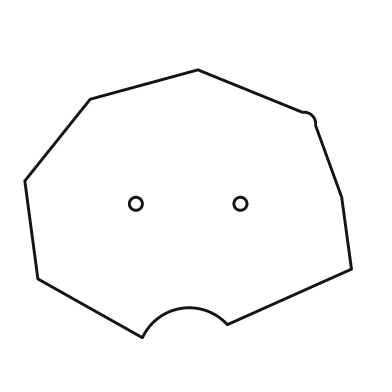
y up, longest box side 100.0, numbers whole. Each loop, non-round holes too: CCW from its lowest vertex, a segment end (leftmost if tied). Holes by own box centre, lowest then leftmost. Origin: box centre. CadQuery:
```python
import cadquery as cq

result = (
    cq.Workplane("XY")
    .moveTo(-14.0, -41.0)
    .threePointArc((-2.0, -32.0), (12.0, -37.0))
    .lineTo(50.0, -20.0)
    .lineTo(47.0, 2.0)
    .lineTo(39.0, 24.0)
    .threePointArc((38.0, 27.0), (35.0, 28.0))
    .lineTo(3.0, 41.0)
    .lineTo(-30.0, 32.0)
    .lineTo(-50.0, 7.0)
    .lineTo(-46.0, -23.0)
    .close()
    .moveTo(-16.0, 0.0)
    .circle(2.0)
    .moveTo(16.0, 0.0)
    .circle(2.0)
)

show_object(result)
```